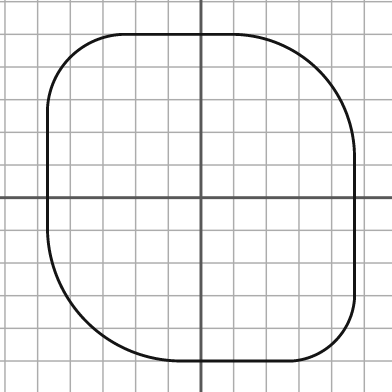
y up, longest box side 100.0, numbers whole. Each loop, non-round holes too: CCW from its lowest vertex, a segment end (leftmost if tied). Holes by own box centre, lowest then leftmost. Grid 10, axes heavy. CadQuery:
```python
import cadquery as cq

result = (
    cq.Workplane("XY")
    .moveTo(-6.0, -50.0)
    .lineTo(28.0, -50.0)
    .threePointArc((41.0, -44.0), (47.0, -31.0))
    .lineTo(47.0, 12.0)
    .threePointArc((36.0, 39.0), (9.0, 50.0))
    .lineTo(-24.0, 50.0)
    .threePointArc((-40.0, 43.0), (-47.0, 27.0))
    .lineTo(-47.0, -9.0)
    .threePointArc((-35.0, -38.0), (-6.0, -50.0))
    .close()
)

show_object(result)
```